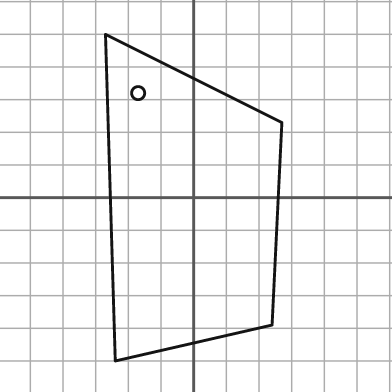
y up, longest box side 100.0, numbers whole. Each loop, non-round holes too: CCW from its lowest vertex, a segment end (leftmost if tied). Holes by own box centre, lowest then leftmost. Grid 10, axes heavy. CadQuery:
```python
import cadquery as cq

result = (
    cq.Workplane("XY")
    .moveTo(-24.0, -50.0)
    .lineTo(24.0, -39.0)
    .lineTo(27.0, 23.0)
    .lineTo(-27.0, 50.0)
    .close()
    .moveTo(-17.0, 32.0)
    .circle(2.0)
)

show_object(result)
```